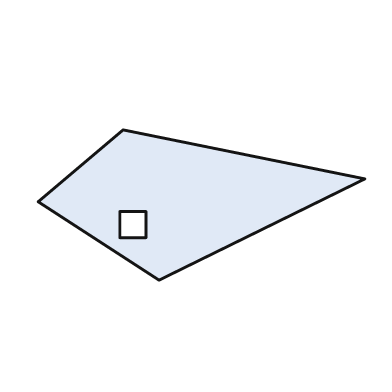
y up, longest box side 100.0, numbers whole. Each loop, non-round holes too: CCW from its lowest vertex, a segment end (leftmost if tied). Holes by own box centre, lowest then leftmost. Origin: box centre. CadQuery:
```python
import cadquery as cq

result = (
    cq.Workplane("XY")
    .moveTo(-13.0, -23.0)
    .lineTo(50.0, 8.0)
    .lineTo(-24.0, 23.0)
    .lineTo(-50.0, 1.0)
    .close()
    .moveTo(-25.0, -10.0)
    .lineTo(-17.0, -10.0)
    .lineTo(-17.0, -2.0)
    .lineTo(-25.0, -2.0)
    .close()
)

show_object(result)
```